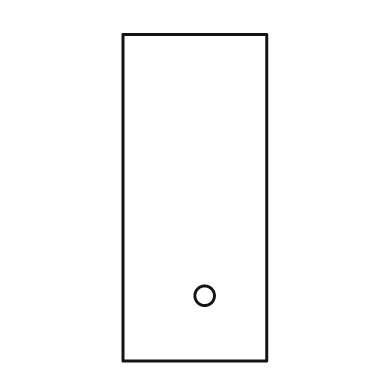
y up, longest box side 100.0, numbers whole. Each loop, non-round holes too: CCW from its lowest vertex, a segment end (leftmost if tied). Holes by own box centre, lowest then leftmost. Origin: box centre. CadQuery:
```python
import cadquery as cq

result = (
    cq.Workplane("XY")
    .moveTo(-22.0, -50.0)
    .lineTo(22.0, -50.0)
    .lineTo(22.0, 50.0)
    .lineTo(-22.0, 50.0)
    .close()
    .moveTo(3.0, -30.0)
    .circle(3.0)
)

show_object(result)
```